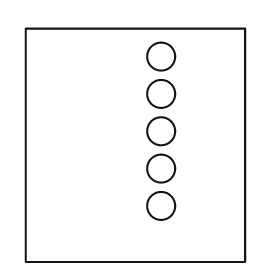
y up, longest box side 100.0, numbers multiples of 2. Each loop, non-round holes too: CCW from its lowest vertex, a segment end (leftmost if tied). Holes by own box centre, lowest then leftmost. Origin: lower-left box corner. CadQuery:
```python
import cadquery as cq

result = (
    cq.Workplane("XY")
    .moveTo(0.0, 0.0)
    .lineTo(94.0, 0.0)
    .lineTo(94.0, 100.0)
    .lineTo(0.0, 100.0)
    .close()
    .moveTo(58.0, 24.0)
    .circle(6.0)
    .moveTo(58.0, 40.0)
    .circle(6.0)
    .moveTo(58.0, 56.0)
    .circle(6.0)
    .moveTo(58.0, 72.0)
    .circle(6.0)
    .moveTo(58.0, 88.0)
    .circle(6.0)
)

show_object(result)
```